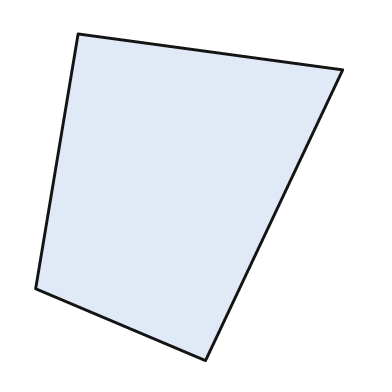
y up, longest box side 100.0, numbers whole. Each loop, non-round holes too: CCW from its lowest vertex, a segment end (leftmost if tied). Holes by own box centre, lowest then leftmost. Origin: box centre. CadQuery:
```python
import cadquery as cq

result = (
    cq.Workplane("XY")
    .moveTo(5.0, -50.0)
    .lineTo(47.0, 39.0)
    .lineTo(-34.0, 50.0)
    .lineTo(-47.0, -28.0)
    .close()
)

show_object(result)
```